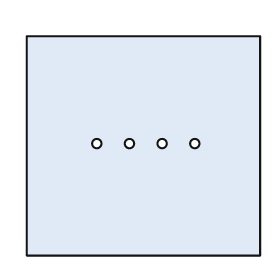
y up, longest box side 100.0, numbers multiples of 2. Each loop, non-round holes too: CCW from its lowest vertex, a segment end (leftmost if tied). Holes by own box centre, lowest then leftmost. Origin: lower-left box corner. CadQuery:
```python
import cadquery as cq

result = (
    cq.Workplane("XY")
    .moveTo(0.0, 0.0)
    .lineTo(100.0, 0.0)
    .lineTo(100.0, 94.0)
    .lineTo(0.0, 94.0)
    .close()
    .moveTo(30.0, 48.0)
    .circle(2.0)
    .moveTo(44.0, 48.0)
    .circle(2.0)
    .moveTo(58.0, 48.0)
    .circle(2.0)
    .moveTo(72.0, 48.0)
    .circle(2.0)
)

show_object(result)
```